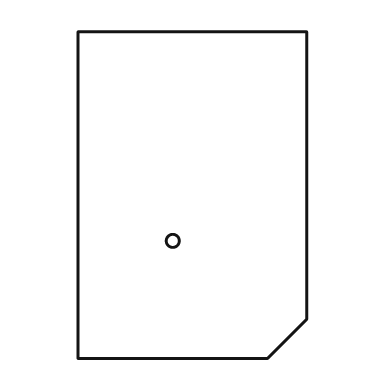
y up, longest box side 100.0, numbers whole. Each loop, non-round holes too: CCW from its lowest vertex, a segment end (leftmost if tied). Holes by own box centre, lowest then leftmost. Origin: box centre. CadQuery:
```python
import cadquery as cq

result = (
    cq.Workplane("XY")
    .moveTo(-35.0, -50.0)
    .lineTo(23.0, -50.0)
    .lineTo(35.0, -38.0)
    .lineTo(35.0, 50.0)
    .lineTo(-35.0, 50.0)
    .close()
    .moveTo(-6.0, -14.0)
    .circle(2.0)
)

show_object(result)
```